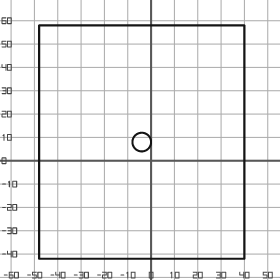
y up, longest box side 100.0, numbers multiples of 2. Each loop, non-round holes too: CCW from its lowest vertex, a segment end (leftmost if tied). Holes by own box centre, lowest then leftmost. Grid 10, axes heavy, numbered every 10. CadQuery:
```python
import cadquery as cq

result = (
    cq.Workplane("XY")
    .moveTo(-48.0, -42.0)
    .lineTo(40.0, -42.0)
    .lineTo(40.0, 58.0)
    .lineTo(-48.0, 58.0)
    .close()
    .moveTo(-4.0, 8.0)
    .circle(4.0)
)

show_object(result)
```